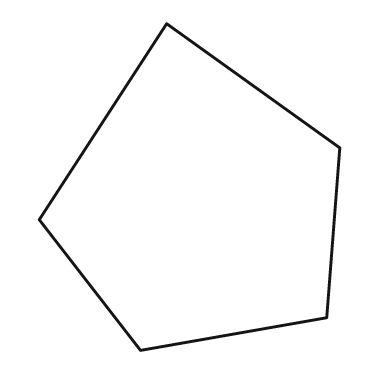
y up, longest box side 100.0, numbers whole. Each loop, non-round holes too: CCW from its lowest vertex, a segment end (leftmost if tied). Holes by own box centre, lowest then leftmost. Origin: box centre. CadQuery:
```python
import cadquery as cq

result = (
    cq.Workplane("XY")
    .moveTo(-15.0, -50.0)
    .lineTo(42.0, -40.0)
    .lineTo(46.0, 12.0)
    .lineTo(-7.0, 50.0)
    .lineTo(-46.0, -10.0)
    .close()
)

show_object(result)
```